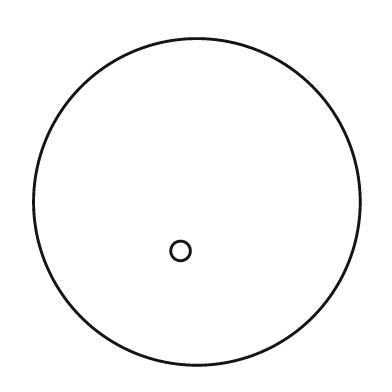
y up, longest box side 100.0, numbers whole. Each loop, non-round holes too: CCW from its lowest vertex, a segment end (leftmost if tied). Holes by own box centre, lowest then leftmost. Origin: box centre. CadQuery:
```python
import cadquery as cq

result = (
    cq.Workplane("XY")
    .moveTo(0.0, 0.0)
    .circle(50.0)
    .moveTo(-5.0, -15.0)
    .circle(3.0)
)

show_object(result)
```